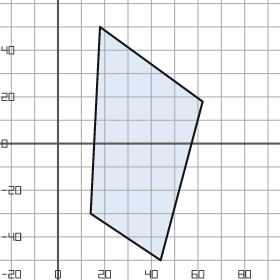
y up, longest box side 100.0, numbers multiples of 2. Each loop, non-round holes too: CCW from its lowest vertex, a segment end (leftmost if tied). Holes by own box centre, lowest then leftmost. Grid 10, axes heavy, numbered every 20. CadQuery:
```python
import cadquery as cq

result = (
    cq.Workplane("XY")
    .moveTo(44.0, -50.0)
    .lineTo(62.0, 18.0)
    .lineTo(18.0, 50.0)
    .lineTo(14.0, -30.0)
    .close()
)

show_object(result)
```